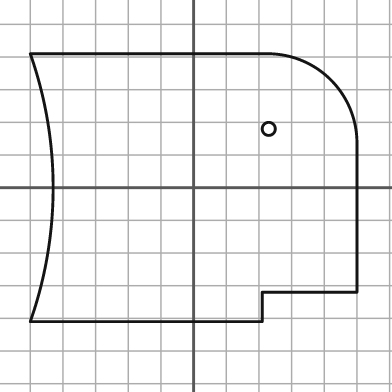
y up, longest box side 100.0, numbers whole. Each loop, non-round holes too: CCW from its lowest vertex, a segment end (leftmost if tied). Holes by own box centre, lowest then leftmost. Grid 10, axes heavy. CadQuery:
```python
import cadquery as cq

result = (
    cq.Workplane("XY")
    .moveTo(-50.0, -41.0)
    .lineTo(21.0, -41.0)
    .lineTo(21.0, -32.0)
    .lineTo(50.0, -32.0)
    .lineTo(50.0, 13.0)
    .threePointArc((42.0, 33.0), (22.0, 41.0))
    .lineTo(-50.0, 41.0)
    .threePointArc((-43.0, 0.0), (-50.0, -41.0))
    .close()
    .moveTo(23.0, 18.0)
    .circle(2.0)
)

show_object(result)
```